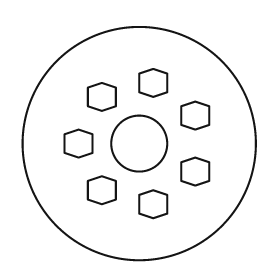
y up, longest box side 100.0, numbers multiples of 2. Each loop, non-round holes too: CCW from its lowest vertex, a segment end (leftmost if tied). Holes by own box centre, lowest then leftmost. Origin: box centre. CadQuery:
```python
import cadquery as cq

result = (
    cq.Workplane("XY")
    .moveTo(0.0, 0.0)
    .circle(50.0)
    .moveTo(6.0, -32.0)
    .lineTo(12.0, -30.0)
    .lineTo(12.0, -22.0)
    .lineTo(6.0, -20.0)
    .lineTo(0.0, -22.0)
    .lineTo(0.0, -30.0)
    .close()
    .moveTo(-16.0, -26.0)
    .lineTo(-10.0, -24.0)
    .lineTo(-10.0, -16.0)
    .lineTo(-16.0, -14.0)
    .lineTo(-22.0, -16.0)
    .lineTo(-22.0, -24.0)
    .close()
    .moveTo(24.0, -18.0)
    .lineTo(30.0, -16.0)
    .lineTo(30.0, -8.0)
    .lineTo(24.0, -6.0)
    .lineTo(18.0, -8.0)
    .lineTo(18.0, -16.0)
    .close()
    .moveTo(-26.0, -6.0)
    .lineTo(-20.0, -4.0)
    .lineTo(-20.0, 4.0)
    .lineTo(-26.0, 6.0)
    .lineTo(-32.0, 4.0)
    .lineTo(-32.0, -4.0)
    .close()
    .moveTo(0.0, 0.0)
    .circle(12.0)
    .moveTo(24.0, 6.0)
    .lineTo(30.0, 8.0)
    .lineTo(30.0, 16.0)
    .lineTo(24.0, 18.0)
    .lineTo(18.0, 16.0)
    .lineTo(18.0, 8.0)
    .close()
    .moveTo(-16.0, 14.0)
    .lineTo(-10.0, 16.0)
    .lineTo(-10.0, 24.0)
    .lineTo(-16.0, 26.0)
    .lineTo(-22.0, 24.0)
    .lineTo(-22.0, 16.0)
    .close()
    .moveTo(6.0, 20.0)
    .lineTo(12.0, 22.0)
    .lineTo(12.0, 30.0)
    .lineTo(6.0, 32.0)
    .lineTo(0.0, 30.0)
    .lineTo(0.0, 22.0)
    .close()
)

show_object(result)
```